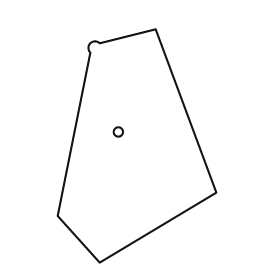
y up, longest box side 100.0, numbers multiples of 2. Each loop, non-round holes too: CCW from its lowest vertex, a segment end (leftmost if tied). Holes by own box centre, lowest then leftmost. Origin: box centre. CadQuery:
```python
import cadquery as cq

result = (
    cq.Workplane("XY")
    .moveTo(-16.0, -50.0)
    .lineTo(34.0, -20.0)
    .lineTo(8.0, 50.0)
    .lineTo(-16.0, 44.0)
    .threePointArc((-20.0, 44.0), (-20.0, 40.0))
    .lineTo(-34.0, -30.0)
    .close()
    .moveTo(-8.0, 6.0)
    .circle(2.0)
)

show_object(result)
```